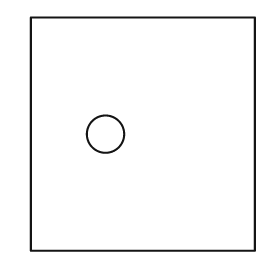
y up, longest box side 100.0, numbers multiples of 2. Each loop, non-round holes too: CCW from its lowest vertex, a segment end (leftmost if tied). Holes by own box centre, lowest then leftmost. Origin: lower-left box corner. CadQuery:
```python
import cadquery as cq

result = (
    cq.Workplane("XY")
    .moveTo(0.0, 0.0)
    .lineTo(96.0, 0.0)
    .lineTo(96.0, 100.0)
    .lineTo(0.0, 100.0)
    .close()
    .moveTo(32.0, 50.0)
    .circle(8.0)
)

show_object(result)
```